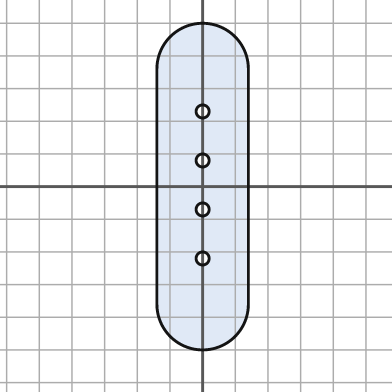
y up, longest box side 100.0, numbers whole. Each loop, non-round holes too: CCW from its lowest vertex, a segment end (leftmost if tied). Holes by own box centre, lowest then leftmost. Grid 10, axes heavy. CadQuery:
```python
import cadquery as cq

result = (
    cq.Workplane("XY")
    .moveTo(-14.0, -36.0)
    .threePointArc((0.0, -50.0), (14.0, -36.0))
    .lineTo(14.0, 36.0)
    .threePointArc((0.0, 50.0), (-14.0, 36.0))
    .close()
    .moveTo(0.0, -22.0)
    .circle(2.0)
    .moveTo(0.0, -7.0)
    .circle(2.0)
    .moveTo(0.0, 8.0)
    .circle(2.0)
    .moveTo(0.0, 23.0)
    .circle(2.0)
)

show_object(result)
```